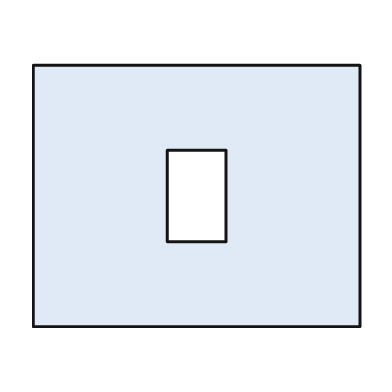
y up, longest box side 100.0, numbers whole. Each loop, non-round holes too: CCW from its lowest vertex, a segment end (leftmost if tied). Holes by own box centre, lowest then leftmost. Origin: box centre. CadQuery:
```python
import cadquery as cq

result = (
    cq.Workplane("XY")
    .moveTo(-50.0, -40.0)
    .lineTo(50.0, -40.0)
    .lineTo(50.0, 40.0)
    .lineTo(-50.0, 40.0)
    .close()
    .moveTo(-9.0, -14.0)
    .lineTo(9.0, -14.0)
    .lineTo(9.0, 14.0)
    .lineTo(-9.0, 14.0)
    .close()
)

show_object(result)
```